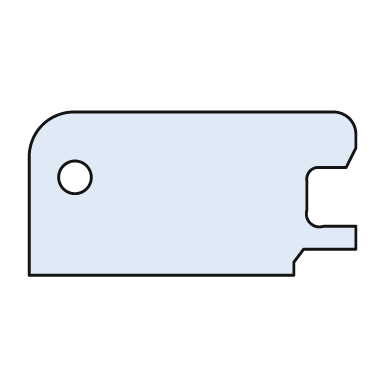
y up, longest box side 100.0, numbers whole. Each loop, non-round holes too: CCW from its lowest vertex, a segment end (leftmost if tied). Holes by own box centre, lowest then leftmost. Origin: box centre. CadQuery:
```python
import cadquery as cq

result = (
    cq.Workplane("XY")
    .moveTo(-50.0, -25.0)
    .lineTo(31.0, -25.0)
    .lineTo(31.0, -21.0)
    .lineTo(34.0, -17.0)
    .lineTo(50.0, -17.0)
    .lineTo(50.0, -10.0)
    .lineTo(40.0, -10.0)
    .threePointArc((36.0, -9.0), (35.0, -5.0))
    .lineTo(35.0, 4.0)
    .threePointArc((36.0, 7.0), (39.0, 8.0))
    .lineTo(47.0, 8.0)
    .lineTo(50.0, 14.0)
    .lineTo(50.0, 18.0)
    .threePointArc((48.0, 23.0), (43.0, 25.0))
    .lineTo(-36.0, 25.0)
    .threePointArc((-46.0, 21.0), (-50.0, 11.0))
    .close()
    .moveTo(-36.0, 5.0)
    .circle(5.0)
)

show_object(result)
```